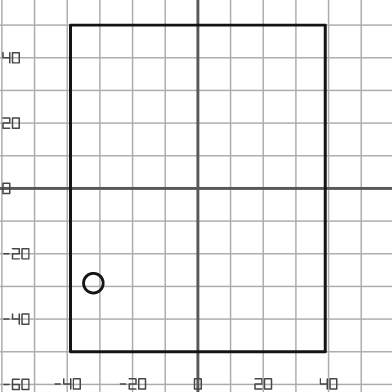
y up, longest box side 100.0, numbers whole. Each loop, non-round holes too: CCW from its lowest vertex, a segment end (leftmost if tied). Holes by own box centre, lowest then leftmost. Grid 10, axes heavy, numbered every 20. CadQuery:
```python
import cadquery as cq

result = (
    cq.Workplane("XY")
    .moveTo(-39.0, -50.0)
    .lineTo(39.0, -50.0)
    .lineTo(39.0, 50.0)
    .lineTo(-39.0, 50.0)
    .close()
    .moveTo(-32.0, -29.0)
    .circle(3.0)
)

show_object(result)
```